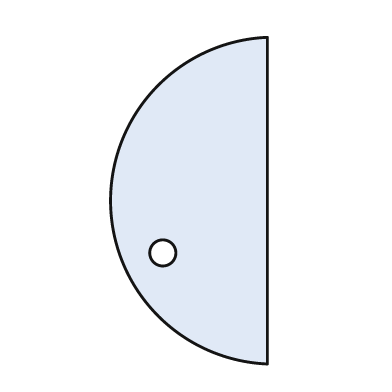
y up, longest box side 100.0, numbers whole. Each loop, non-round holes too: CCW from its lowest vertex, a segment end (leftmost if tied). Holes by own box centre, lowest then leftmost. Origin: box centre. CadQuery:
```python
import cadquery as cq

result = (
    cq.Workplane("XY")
    .moveTo(24.0, -50.0)
    .lineTo(24.0, 50.0)
    .threePointArc((-24.0, 0.0), (24.0, -50.0))
    .close()
    .moveTo(-8.0, -16.0)
    .circle(4.0)
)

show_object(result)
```